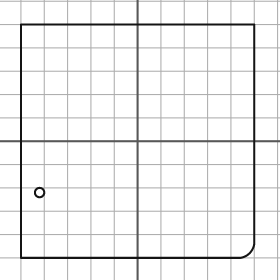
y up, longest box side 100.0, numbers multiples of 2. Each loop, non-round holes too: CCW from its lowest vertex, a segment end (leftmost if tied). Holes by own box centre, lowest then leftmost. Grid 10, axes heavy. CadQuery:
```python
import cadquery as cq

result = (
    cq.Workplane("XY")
    .moveTo(-50.0, -50.0)
    .lineTo(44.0, -50.0)
    .threePointArc((48.0, -48.0), (50.0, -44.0))
    .lineTo(50.0, 50.0)
    .lineTo(-50.0, 50.0)
    .close()
    .moveTo(-42.0, -22.0)
    .circle(2.0)
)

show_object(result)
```